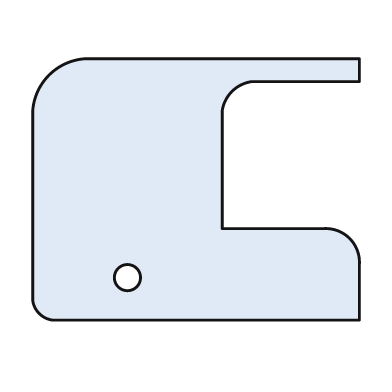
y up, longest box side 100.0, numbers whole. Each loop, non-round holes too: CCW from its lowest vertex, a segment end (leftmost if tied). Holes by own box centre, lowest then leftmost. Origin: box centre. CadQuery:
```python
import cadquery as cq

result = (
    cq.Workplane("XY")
    .moveTo(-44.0, -40.0)
    .lineTo(50.0, -40.0)
    .lineTo(50.0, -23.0)
    .threePointArc((47.0, -15.0), (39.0, -12.0))
    .lineTo(8.0, -12.0)
    .lineTo(8.0, 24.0)
    .threePointArc((11.0, 30.0), (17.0, 33.0))
    .lineTo(50.0, 33.0)
    .lineTo(50.0, 40.0)
    .lineTo(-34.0, 40.0)
    .threePointArc((-45.0, 35.0), (-50.0, 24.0))
    .lineTo(-50.0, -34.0)
    .threePointArc((-48.0, -38.0), (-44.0, -40.0))
    .close()
    .moveTo(-21.0, -27.0)
    .circle(4.0)
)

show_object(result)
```